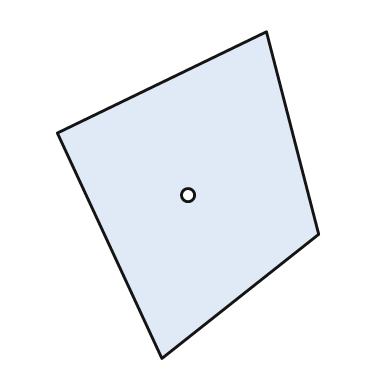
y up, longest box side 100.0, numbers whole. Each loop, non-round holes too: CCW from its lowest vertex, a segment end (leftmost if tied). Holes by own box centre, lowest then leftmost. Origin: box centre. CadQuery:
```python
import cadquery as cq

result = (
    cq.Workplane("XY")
    .moveTo(-8.0, -50.0)
    .lineTo(40.0, -12.0)
    .lineTo(24.0, 50.0)
    .lineTo(-40.0, 19.0)
    .close()
    .moveTo(0.0, 0.0)
    .circle(2.0)
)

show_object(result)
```